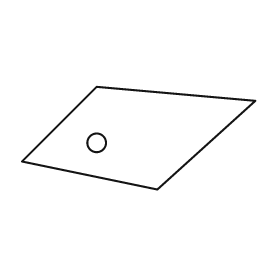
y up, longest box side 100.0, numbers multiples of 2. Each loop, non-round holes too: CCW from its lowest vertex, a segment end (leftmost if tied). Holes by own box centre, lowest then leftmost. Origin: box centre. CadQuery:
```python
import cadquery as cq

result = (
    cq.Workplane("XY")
    .moveTo(8.0, -22.0)
    .lineTo(50.0, 16.0)
    .lineTo(-18.0, 22.0)
    .lineTo(-50.0, -10.0)
    .close()
    .moveTo(-18.0, -2.0)
    .circle(4.0)
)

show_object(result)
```